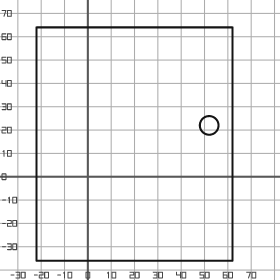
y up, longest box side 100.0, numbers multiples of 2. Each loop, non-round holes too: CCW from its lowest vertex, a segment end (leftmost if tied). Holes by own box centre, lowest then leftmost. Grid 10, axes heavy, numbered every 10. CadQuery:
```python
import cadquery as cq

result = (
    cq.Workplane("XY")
    .moveTo(-22.0, -36.0)
    .lineTo(62.0, -36.0)
    .lineTo(62.0, 64.0)
    .lineTo(-22.0, 64.0)
    .close()
    .moveTo(52.0, 22.0)
    .circle(4.0)
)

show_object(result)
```